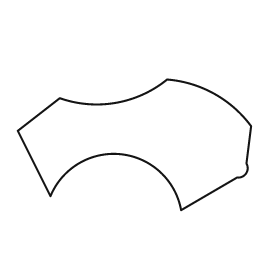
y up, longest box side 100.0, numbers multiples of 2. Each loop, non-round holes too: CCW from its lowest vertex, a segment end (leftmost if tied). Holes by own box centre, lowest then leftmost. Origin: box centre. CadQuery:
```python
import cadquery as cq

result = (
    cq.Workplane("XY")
    .moveTo(20.0, -28.0)
    .lineTo(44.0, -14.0)
    .threePointArc((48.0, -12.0), (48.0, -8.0))
    .lineTo(50.0, 8.0)
    .threePointArc((34.0, 22.0), (14.0, 28.0))
    .threePointArc((-8.0, 18.0), (-32.0, 20.0))
    .lineTo(-50.0, 6.0)
    .lineTo(-36.0, -22.0)
    .threePointArc((-6.0, -4.0), (20.0, -28.0))
    .close()
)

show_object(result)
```